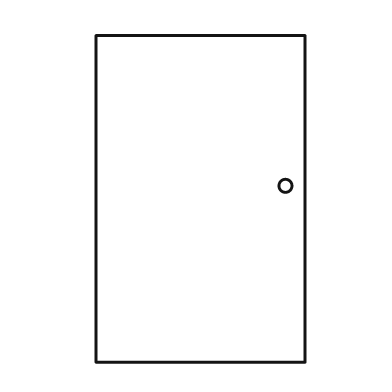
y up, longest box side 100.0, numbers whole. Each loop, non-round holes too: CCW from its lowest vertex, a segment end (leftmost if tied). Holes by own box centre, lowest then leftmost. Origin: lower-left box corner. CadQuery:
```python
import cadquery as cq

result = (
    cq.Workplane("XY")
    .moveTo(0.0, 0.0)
    .lineTo(64.0, 0.0)
    .lineTo(64.0, 100.0)
    .lineTo(0.0, 100.0)
    .close()
    .moveTo(58.0, 54.0)
    .circle(2.0)
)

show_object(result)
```